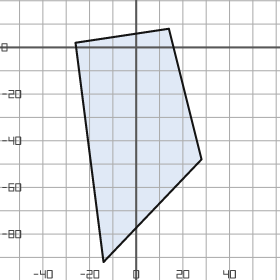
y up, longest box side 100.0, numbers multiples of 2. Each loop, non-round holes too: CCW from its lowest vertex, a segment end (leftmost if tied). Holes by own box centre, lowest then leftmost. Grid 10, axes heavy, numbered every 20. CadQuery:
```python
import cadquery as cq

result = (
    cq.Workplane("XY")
    .moveTo(-14.0, -92.0)
    .lineTo(28.0, -48.0)
    .lineTo(14.0, 8.0)
    .lineTo(-26.0, 2.0)
    .close()
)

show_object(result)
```